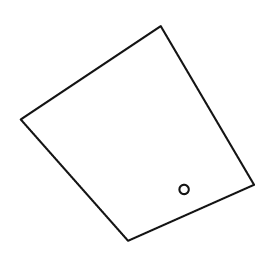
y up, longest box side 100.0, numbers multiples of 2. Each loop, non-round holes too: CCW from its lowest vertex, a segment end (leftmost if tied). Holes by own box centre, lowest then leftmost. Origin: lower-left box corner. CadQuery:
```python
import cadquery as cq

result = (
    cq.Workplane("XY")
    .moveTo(46.0, 0.0)
    .lineTo(100.0, 24.0)
    .lineTo(60.0, 92.0)
    .lineTo(0.0, 52.0)
    .close()
    .moveTo(70.0, 22.0)
    .circle(2.0)
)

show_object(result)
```